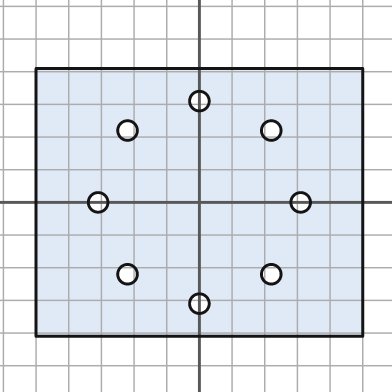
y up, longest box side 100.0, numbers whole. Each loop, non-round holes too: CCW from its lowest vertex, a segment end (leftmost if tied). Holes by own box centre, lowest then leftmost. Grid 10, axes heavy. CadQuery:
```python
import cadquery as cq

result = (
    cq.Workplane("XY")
    .moveTo(-50.0, -41.0)
    .lineTo(50.0, -41.0)
    .lineTo(50.0, 41.0)
    .lineTo(-50.0, 41.0)
    .close()
    .moveTo(0.0, -31.0)
    .circle(3.0)
    .moveTo(-22.0, -22.0)
    .circle(3.0)
    .moveTo(22.0, -22.0)
    .circle(3.0)
    .moveTo(-31.0, 0.0)
    .circle(3.0)
    .moveTo(31.0, 0.0)
    .circle(3.0)
    .moveTo(-22.0, 22.0)
    .circle(3.0)
    .moveTo(22.0, 22.0)
    .circle(3.0)
    .moveTo(0.0, 31.0)
    .circle(3.0)
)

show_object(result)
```